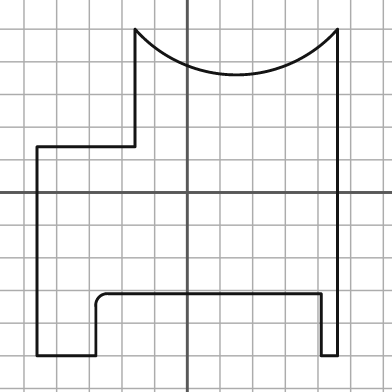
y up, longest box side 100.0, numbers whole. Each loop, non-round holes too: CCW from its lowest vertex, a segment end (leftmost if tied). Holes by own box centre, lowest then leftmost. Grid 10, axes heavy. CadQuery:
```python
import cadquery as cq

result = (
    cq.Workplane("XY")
    .moveTo(-46.0, -50.0)
    .lineTo(-28.0, -50.0)
    .lineTo(-28.0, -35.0)
    .threePointArc((-27.0, -32.0), (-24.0, -31.0))
    .lineTo(41.0, -31.0)
    .lineTo(41.0, -50.0)
    .lineTo(46.0, -50.0)
    .lineTo(46.0, 50.0)
    .threePointArc((15.0, 36.0), (-16.0, 50.0))
    .lineTo(-16.0, 14.0)
    .lineTo(-46.0, 14.0)
    .close()
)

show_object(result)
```